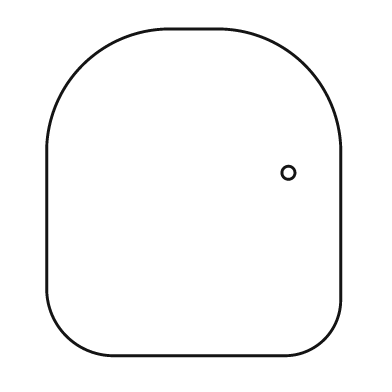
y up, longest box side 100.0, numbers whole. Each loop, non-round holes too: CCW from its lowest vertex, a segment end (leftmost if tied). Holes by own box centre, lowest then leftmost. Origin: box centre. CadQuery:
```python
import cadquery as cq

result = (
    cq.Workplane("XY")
    .moveTo(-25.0, -50.0)
    .lineTo(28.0, -50.0)
    .threePointArc((40.0, -45.0), (45.0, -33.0))
    .lineTo(45.0, 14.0)
    .threePointArc((34.0, 39.0), (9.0, 50.0))
    .lineTo(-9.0, 50.0)
    .threePointArc((-34.0, 39.0), (-45.0, 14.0))
    .lineTo(-45.0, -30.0)
    .threePointArc((-39.0, -44.0), (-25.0, -50.0))
    .close()
    .moveTo(29.0, 6.0)
    .circle(2.0)
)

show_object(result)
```